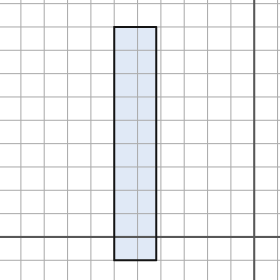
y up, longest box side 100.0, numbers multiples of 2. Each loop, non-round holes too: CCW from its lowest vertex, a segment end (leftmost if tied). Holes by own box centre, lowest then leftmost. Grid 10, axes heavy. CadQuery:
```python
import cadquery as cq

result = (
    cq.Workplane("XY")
    .moveTo(-60.0, -10.0)
    .lineTo(-42.0, -10.0)
    .lineTo(-42.0, 90.0)
    .lineTo(-60.0, 90.0)
    .close()
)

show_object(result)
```